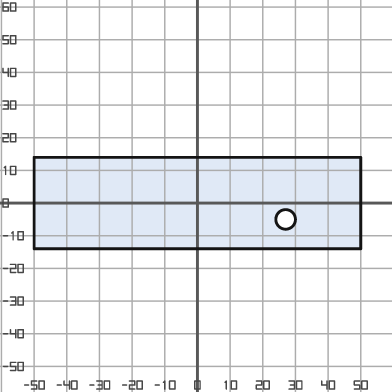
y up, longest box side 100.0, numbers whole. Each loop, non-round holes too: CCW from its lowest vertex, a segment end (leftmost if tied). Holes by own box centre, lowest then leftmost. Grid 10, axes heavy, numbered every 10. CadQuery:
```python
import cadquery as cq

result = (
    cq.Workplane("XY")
    .moveTo(-50.0, -14.0)
    .lineTo(50.0, -14.0)
    .lineTo(50.0, 14.0)
    .lineTo(-50.0, 14.0)
    .close()
    .moveTo(27.0, -5.0)
    .circle(3.0)
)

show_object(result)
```